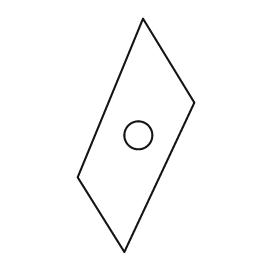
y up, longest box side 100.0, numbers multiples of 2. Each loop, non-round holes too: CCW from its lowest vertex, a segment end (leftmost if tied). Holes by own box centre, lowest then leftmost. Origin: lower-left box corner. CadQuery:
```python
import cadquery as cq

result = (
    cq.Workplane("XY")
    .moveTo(20.0, 0.0)
    .lineTo(50.0, 64.0)
    .lineTo(28.0, 100.0)
    .lineTo(0.0, 32.0)
    .close()
    .moveTo(26.0, 50.0)
    .circle(6.0)
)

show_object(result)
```